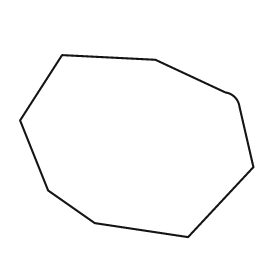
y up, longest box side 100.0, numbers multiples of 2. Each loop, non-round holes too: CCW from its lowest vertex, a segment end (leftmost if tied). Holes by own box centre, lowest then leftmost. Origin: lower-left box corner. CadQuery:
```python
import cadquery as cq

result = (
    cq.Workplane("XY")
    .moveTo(72.0, 0.0)
    .lineTo(100.0, 30.0)
    .lineTo(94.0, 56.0)
    .threePointArc((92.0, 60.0), (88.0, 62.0))
    .lineTo(58.0, 76.0)
    .lineTo(18.0, 78.0)
    .lineTo(0.0, 50.0)
    .lineTo(12.0, 20.0)
    .lineTo(32.0, 6.0)
    .close()
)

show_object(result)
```